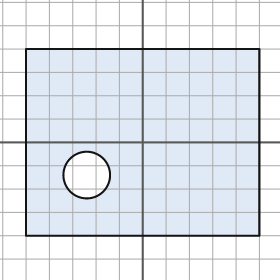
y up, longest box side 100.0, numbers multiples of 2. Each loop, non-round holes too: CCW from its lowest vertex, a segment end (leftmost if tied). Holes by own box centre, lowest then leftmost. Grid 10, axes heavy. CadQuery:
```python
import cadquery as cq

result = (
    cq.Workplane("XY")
    .moveTo(-50.0, -40.0)
    .lineTo(50.0, -40.0)
    .lineTo(50.0, 40.0)
    .lineTo(-50.0, 40.0)
    .close()
    .moveTo(-24.0, -14.0)
    .circle(10.0)
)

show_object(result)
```